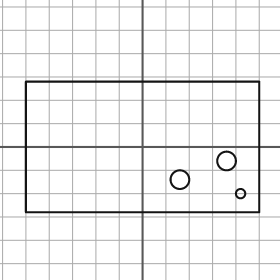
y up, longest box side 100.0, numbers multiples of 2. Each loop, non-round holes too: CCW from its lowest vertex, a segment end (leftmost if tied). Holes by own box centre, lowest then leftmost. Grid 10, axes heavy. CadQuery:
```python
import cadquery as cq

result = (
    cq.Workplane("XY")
    .moveTo(-50.0, -28.0)
    .lineTo(50.0, -28.0)
    .lineTo(50.0, 28.0)
    .lineTo(-50.0, 28.0)
    .close()
    .moveTo(42.0, -20.0)
    .circle(2.0)
    .moveTo(16.0, -14.0)
    .circle(4.0)
    .moveTo(36.0, -6.0)
    .circle(4.0)
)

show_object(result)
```